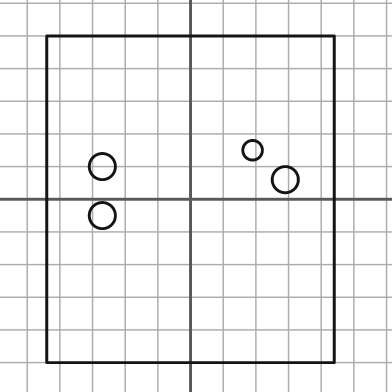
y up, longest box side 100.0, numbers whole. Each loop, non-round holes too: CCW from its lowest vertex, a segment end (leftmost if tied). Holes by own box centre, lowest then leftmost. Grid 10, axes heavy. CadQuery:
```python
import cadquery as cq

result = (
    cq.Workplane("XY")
    .moveTo(-44.0, -50.0)
    .lineTo(44.0, -50.0)
    .lineTo(44.0, 50.0)
    .lineTo(-44.0, 50.0)
    .close()
    .moveTo(-27.0, -5.0)
    .circle(4.0)
    .moveTo(29.0, 6.0)
    .circle(4.0)
    .moveTo(-27.0, 10.0)
    .circle(4.0)
    .moveTo(19.0, 15.0)
    .circle(3.0)
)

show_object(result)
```